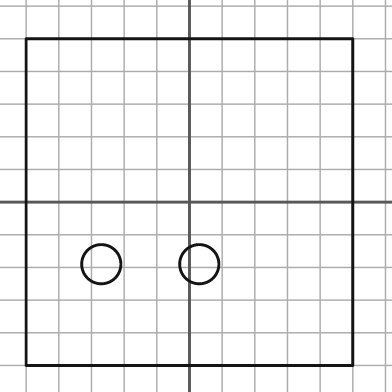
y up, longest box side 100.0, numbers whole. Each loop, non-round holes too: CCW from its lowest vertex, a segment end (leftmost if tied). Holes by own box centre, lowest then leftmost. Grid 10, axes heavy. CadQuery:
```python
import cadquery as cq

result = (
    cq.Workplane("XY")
    .moveTo(-50.0, -50.0)
    .lineTo(50.0, -50.0)
    .lineTo(50.0, 50.0)
    .lineTo(-50.0, 50.0)
    .close()
    .moveTo(-27.0, -19.0)
    .circle(6.0)
    .moveTo(3.0, -19.0)
    .circle(6.0)
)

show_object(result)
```